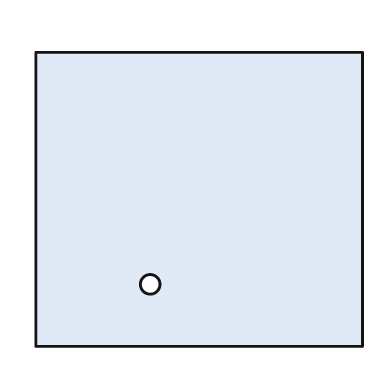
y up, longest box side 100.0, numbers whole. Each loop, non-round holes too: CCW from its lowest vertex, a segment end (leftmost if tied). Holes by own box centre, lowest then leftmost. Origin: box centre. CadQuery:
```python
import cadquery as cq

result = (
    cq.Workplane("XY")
    .moveTo(-50.0, -45.0)
    .lineTo(50.0, -45.0)
    .lineTo(50.0, 45.0)
    .lineTo(-50.0, 45.0)
    .close()
    .moveTo(-15.0, -26.0)
    .circle(3.0)
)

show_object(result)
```